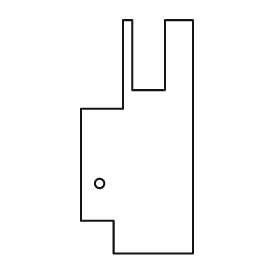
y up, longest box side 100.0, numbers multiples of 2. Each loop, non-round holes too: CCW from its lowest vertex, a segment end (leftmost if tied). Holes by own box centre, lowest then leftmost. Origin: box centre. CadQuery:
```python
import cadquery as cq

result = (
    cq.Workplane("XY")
    .moveTo(-10.0, -50.0)
    .lineTo(24.0, -50.0)
    .lineTo(24.0, 50.0)
    .lineTo(12.0, 50.0)
    .lineTo(12.0, 20.0)
    .lineTo(-2.0, 20.0)
    .lineTo(-2.0, 50.0)
    .lineTo(-6.0, 50.0)
    .lineTo(-6.0, 12.0)
    .lineTo(-24.0, 12.0)
    .lineTo(-24.0, -36.0)
    .lineTo(-10.0, -36.0)
    .close()
    .moveTo(-16.0, -20.0)
    .circle(2.0)
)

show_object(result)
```